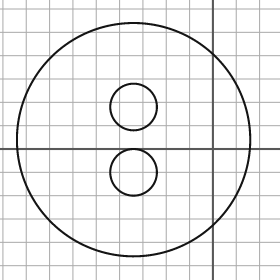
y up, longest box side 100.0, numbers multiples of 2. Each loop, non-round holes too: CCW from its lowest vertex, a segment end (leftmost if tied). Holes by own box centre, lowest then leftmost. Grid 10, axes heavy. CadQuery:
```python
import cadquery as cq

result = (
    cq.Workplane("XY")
    .moveTo(-34.0, 4.0)
    .circle(50.0)
    .moveTo(-34.0, -10.0)
    .circle(10.0)
    .moveTo(-34.0, 18.0)
    .circle(10.0)
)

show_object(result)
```